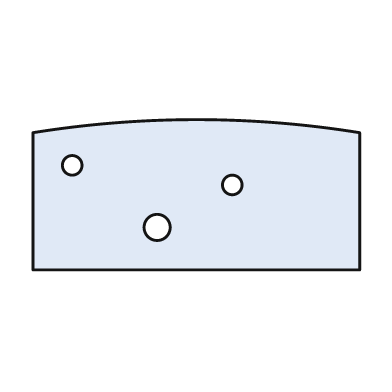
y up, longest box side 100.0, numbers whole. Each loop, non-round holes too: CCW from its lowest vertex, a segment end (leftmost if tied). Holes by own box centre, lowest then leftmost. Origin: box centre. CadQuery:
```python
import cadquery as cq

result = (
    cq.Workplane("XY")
    .moveTo(-50.0, -23.0)
    .lineTo(50.0, -23.0)
    .lineTo(50.0, 19.0)
    .threePointArc((0.0, 23.0), (-50.0, 19.0))
    .close()
    .moveTo(-12.0, -10.0)
    .circle(4.0)
    .moveTo(11.0, 3.0)
    .circle(3.0)
    .moveTo(-38.0, 9.0)
    .circle(3.0)
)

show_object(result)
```